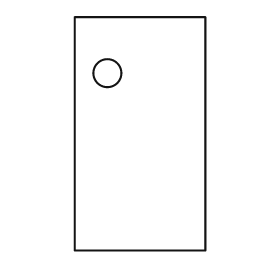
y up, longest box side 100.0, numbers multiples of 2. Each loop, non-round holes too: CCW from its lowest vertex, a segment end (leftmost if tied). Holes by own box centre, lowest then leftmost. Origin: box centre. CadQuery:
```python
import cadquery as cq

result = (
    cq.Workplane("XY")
    .moveTo(-28.0, -50.0)
    .lineTo(28.0, -50.0)
    .lineTo(28.0, 50.0)
    .lineTo(-28.0, 50.0)
    .close()
    .moveTo(-14.0, 26.0)
    .circle(6.0)
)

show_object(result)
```